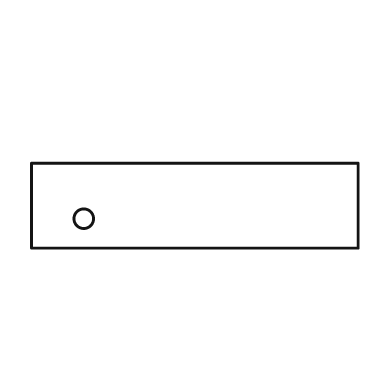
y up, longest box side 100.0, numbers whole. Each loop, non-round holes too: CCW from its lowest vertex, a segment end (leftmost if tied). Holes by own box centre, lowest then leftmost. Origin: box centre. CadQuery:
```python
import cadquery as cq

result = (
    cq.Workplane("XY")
    .moveTo(-50.0, -13.0)
    .lineTo(50.0, -13.0)
    .lineTo(50.0, 13.0)
    .lineTo(-50.0, 13.0)
    .close()
    .moveTo(-34.0, -4.0)
    .circle(3.0)
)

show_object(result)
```